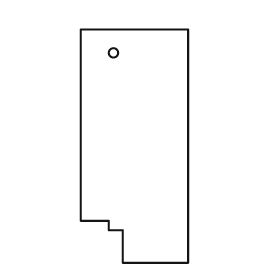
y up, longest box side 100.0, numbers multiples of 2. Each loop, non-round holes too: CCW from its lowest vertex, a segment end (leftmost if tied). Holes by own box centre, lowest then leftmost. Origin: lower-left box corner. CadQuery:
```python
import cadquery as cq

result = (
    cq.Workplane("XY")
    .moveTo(18.0, 0.0)
    .lineTo(46.0, 0.0)
    .lineTo(46.0, 100.0)
    .lineTo(0.0, 100.0)
    .lineTo(0.0, 18.0)
    .lineTo(12.0, 18.0)
    .lineTo(12.0, 14.0)
    .lineTo(18.0, 14.0)
    .close()
    .moveTo(14.0, 90.0)
    .circle(2.0)
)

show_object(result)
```